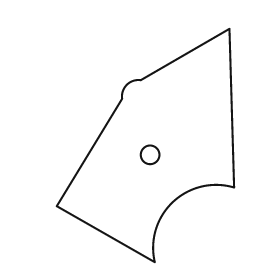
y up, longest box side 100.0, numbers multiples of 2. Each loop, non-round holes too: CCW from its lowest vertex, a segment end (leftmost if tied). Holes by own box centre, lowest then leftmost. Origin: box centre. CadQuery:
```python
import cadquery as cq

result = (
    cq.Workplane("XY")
    .moveTo(4.0, -50.0)
    .threePointArc((12.0, -24.0), (38.0, -18.0))
    .lineTo(36.0, 50.0)
    .lineTo(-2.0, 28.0)
    .threePointArc((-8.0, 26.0), (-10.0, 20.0))
    .lineTo(-38.0, -26.0)
    .close()
    .moveTo(2.0, -4.0)
    .circle(4.0)
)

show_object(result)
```